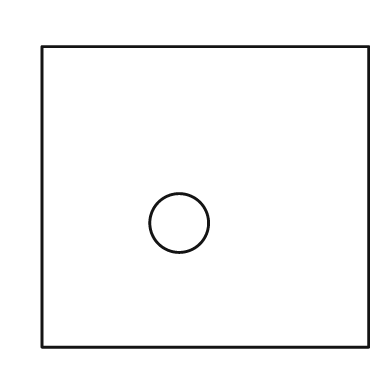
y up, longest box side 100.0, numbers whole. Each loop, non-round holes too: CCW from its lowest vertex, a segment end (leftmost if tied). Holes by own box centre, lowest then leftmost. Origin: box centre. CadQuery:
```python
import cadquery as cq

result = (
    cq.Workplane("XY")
    .moveTo(-50.0, -46.0)
    .lineTo(50.0, -46.0)
    .lineTo(50.0, 46.0)
    .lineTo(-50.0, 46.0)
    .close()
    .moveTo(-8.0, -8.0)
    .circle(9.0)
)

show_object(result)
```